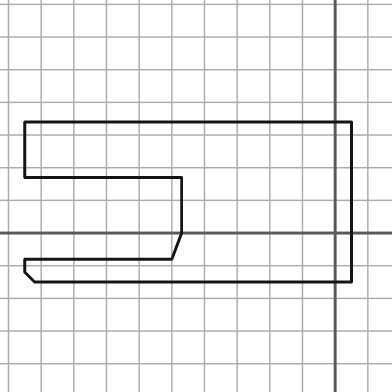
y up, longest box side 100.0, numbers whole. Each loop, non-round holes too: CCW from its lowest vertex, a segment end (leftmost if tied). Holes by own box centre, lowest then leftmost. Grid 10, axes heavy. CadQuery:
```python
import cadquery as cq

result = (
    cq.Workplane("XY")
    .moveTo(-92.0, -15.0)
    .lineTo(5.0, -15.0)
    .lineTo(5.0, 34.0)
    .lineTo(-95.0, 34.0)
    .lineTo(-95.0, 17.0)
    .lineTo(-47.0, 17.0)
    .lineTo(-47.0, 0.0)
    .lineTo(-50.0, -8.0)
    .lineTo(-95.0, -8.0)
    .lineTo(-95.0, -12.0)
    .close()
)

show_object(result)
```